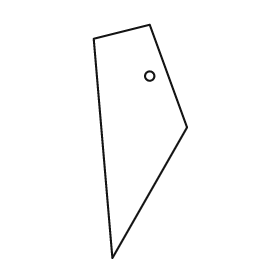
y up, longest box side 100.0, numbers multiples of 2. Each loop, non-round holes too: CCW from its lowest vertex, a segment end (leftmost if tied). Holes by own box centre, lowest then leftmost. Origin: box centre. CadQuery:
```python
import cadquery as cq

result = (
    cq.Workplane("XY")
    .moveTo(-12.0, -50.0)
    .lineTo(20.0, 6.0)
    .lineTo(4.0, 50.0)
    .lineTo(-20.0, 44.0)
    .close()
    .moveTo(4.0, 28.0)
    .circle(2.0)
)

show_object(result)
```